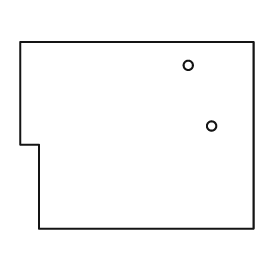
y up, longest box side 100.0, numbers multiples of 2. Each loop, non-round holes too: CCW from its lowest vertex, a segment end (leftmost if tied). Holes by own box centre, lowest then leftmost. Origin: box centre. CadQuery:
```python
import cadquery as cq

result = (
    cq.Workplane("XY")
    .moveTo(-42.0, -40.0)
    .lineTo(50.0, -40.0)
    .lineTo(50.0, 40.0)
    .lineTo(-50.0, 40.0)
    .lineTo(-50.0, -4.0)
    .lineTo(-42.0, -4.0)
    .close()
    .moveTo(32.0, 4.0)
    .circle(2.0)
    .moveTo(22.0, 30.0)
    .circle(2.0)
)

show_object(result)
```